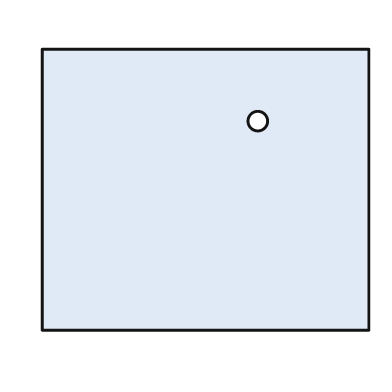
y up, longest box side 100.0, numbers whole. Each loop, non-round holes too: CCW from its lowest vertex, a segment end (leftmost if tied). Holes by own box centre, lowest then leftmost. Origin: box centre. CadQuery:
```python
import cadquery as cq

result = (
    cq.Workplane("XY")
    .moveTo(-50.0, -43.0)
    .lineTo(50.0, -43.0)
    .lineTo(50.0, 43.0)
    .lineTo(-50.0, 43.0)
    .close()
    .moveTo(16.0, 21.0)
    .circle(3.0)
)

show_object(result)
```